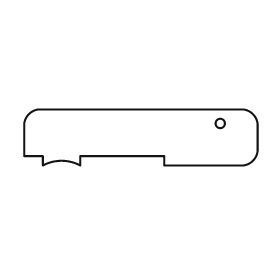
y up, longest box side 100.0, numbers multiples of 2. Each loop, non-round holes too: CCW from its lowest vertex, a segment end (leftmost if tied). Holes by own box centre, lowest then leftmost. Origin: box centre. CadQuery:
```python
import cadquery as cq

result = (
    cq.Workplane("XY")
    .moveTo(-42.0, -12.0)
    .threePointArc((-34.0, -10.0), (-26.0, -12.0))
    .lineTo(-26.0, -8.0)
    .lineTo(10.0, -8.0)
    .lineTo(10.0, -12.0)
    .lineTo(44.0, -12.0)
    .threePointArc((48.0, -10.0), (50.0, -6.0))
    .lineTo(50.0, 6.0)
    .threePointArc((48.0, 10.0), (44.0, 12.0))
    .lineTo(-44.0, 12.0)
    .threePointArc((-48.0, 10.0), (-50.0, 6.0))
    .lineTo(-50.0, -8.0)
    .lineTo(-42.0, -8.0)
    .close()
    .moveTo(34.0, 6.0)
    .circle(2.0)
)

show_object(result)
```